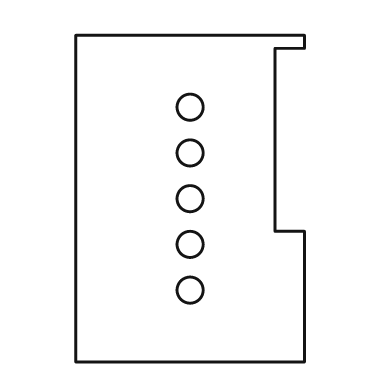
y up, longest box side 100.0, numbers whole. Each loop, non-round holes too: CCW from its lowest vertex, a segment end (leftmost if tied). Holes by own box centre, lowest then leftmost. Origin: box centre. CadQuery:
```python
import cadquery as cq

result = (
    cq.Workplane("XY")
    .moveTo(-35.0, -50.0)
    .lineTo(35.0, -50.0)
    .lineTo(35.0, -10.0)
    .lineTo(26.0, -10.0)
    .lineTo(26.0, 46.0)
    .lineTo(35.0, 46.0)
    .lineTo(35.0, 50.0)
    .lineTo(-35.0, 50.0)
    .close()
    .moveTo(0.0, -28.0)
    .circle(4.0)
    .moveTo(0.0, -14.0)
    .circle(4.0)
    .moveTo(0.0, 0.0)
    .circle(4.0)
    .moveTo(0.0, 14.0)
    .circle(4.0)
    .moveTo(0.0, 28.0)
    .circle(4.0)
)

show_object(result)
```